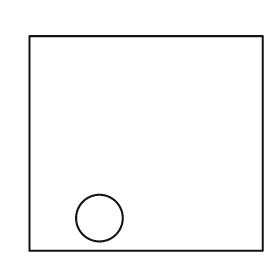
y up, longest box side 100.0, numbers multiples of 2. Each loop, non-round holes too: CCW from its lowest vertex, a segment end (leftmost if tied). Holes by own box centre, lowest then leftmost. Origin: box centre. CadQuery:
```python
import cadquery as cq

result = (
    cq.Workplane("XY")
    .moveTo(-50.0, -46.0)
    .lineTo(50.0, -46.0)
    .lineTo(50.0, 46.0)
    .lineTo(-50.0, 46.0)
    .close()
    .moveTo(-20.0, -32.0)
    .circle(10.0)
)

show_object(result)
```